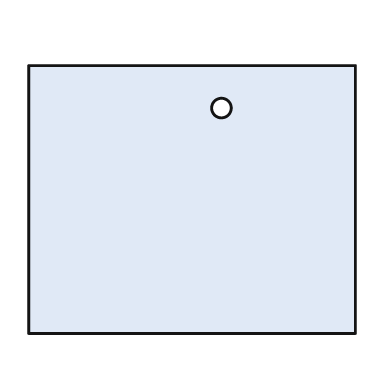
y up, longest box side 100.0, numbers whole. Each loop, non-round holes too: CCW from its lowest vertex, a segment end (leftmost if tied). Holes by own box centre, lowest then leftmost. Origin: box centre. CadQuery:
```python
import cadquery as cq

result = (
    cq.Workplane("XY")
    .moveTo(-50.0, -41.0)
    .lineTo(50.0, -41.0)
    .lineTo(50.0, 41.0)
    .lineTo(-50.0, 41.0)
    .close()
    .moveTo(9.0, 28.0)
    .circle(3.0)
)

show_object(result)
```